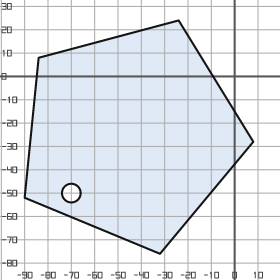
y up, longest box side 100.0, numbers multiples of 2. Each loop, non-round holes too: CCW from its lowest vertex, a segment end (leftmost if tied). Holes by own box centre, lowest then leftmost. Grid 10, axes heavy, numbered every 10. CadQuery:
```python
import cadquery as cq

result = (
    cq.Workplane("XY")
    .moveTo(-32.0, -76.0)
    .lineTo(8.0, -28.0)
    .lineTo(-24.0, 24.0)
    .lineTo(-84.0, 8.0)
    .lineTo(-90.0, -52.0)
    .close()
    .moveTo(-70.0, -50.0)
    .circle(4.0)
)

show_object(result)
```